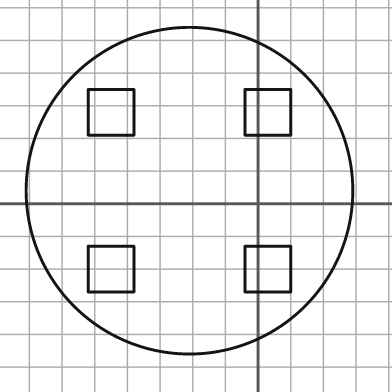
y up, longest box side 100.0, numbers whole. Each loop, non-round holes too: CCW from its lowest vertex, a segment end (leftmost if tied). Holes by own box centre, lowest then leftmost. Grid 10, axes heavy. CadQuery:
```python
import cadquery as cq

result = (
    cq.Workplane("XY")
    .moveTo(-21.0, 4.0)
    .circle(50.0)
    .moveTo(-52.0, -27.0)
    .lineTo(-38.0, -27.0)
    .lineTo(-38.0, -13.0)
    .lineTo(-52.0, -13.0)
    .close()
    .moveTo(-4.0, -27.0)
    .lineTo(10.0, -27.0)
    .lineTo(10.0, -13.0)
    .lineTo(-4.0, -13.0)
    .close()
    .moveTo(-52.0, 21.0)
    .lineTo(-38.0, 21.0)
    .lineTo(-38.0, 35.0)
    .lineTo(-52.0, 35.0)
    .close()
    .moveTo(-4.0, 21.0)
    .lineTo(10.0, 21.0)
    .lineTo(10.0, 35.0)
    .lineTo(-4.0, 35.0)
    .close()
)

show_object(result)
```